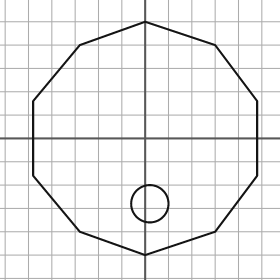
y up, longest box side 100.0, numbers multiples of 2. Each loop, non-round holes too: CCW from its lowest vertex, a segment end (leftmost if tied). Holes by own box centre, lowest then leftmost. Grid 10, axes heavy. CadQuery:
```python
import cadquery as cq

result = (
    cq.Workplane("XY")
    .moveTo(0.0, -50.0)
    .lineTo(30.0, -40.0)
    .lineTo(48.0, -16.0)
    .lineTo(48.0, 16.0)
    .lineTo(30.0, 40.0)
    .lineTo(0.0, 50.0)
    .lineTo(-28.0, 40.0)
    .lineTo(-48.0, 16.0)
    .lineTo(-48.0, -16.0)
    .lineTo(-28.0, -40.0)
    .close()
    .moveTo(2.0, -28.0)
    .circle(8.0)
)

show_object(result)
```